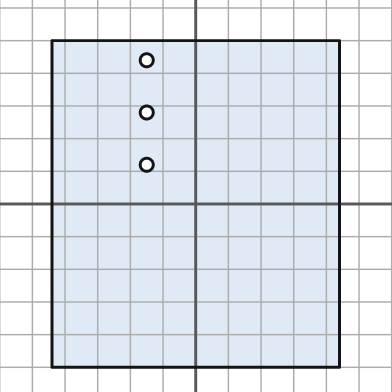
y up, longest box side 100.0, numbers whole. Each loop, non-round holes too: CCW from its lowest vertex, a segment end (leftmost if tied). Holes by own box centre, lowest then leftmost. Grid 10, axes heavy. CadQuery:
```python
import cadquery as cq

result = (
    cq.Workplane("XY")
    .moveTo(-44.0, -50.0)
    .lineTo(44.0, -50.0)
    .lineTo(44.0, 50.0)
    .lineTo(-44.0, 50.0)
    .close()
    .moveTo(-15.0, 12.0)
    .circle(2.0)
    .moveTo(-15.0, 28.0)
    .circle(2.0)
    .moveTo(-15.0, 44.0)
    .circle(2.0)
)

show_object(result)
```